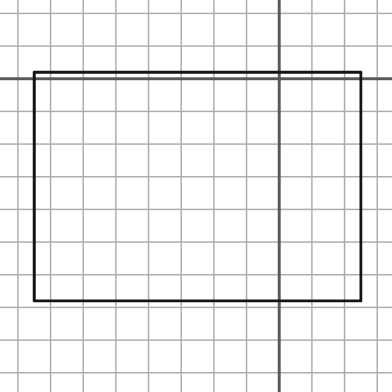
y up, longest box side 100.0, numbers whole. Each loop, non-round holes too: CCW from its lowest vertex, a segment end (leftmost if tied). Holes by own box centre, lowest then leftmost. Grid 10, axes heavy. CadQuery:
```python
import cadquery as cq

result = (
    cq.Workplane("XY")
    .moveTo(-75.0, -68.0)
    .lineTo(25.0, -68.0)
    .lineTo(25.0, 2.0)
    .lineTo(-75.0, 2.0)
    .close()
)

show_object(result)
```